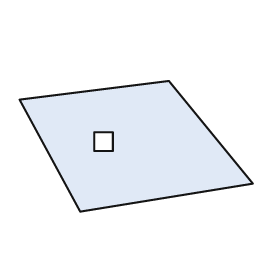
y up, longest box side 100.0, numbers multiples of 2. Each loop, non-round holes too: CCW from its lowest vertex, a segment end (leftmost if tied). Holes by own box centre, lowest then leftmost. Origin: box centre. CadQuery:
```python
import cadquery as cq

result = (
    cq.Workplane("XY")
    .moveTo(-24.0, -28.0)
    .lineTo(50.0, -16.0)
    .lineTo(14.0, 28.0)
    .lineTo(-50.0, 20.0)
    .close()
    .moveTo(-18.0, -2.0)
    .lineTo(-10.0, -2.0)
    .lineTo(-10.0, 6.0)
    .lineTo(-18.0, 6.0)
    .close()
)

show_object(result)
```